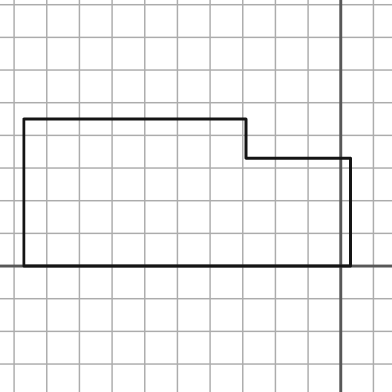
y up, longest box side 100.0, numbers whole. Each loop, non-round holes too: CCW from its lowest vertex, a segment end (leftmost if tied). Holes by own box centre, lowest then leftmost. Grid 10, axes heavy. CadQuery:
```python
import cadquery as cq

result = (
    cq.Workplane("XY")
    .moveTo(-97.0, 0.0)
    .lineTo(3.0, 0.0)
    .lineTo(3.0, 33.0)
    .lineTo(-29.0, 33.0)
    .lineTo(-29.0, 45.0)
    .lineTo(-97.0, 45.0)
    .close()
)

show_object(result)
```